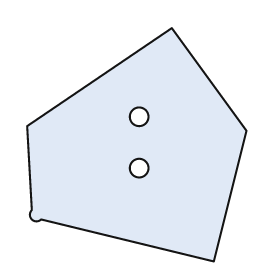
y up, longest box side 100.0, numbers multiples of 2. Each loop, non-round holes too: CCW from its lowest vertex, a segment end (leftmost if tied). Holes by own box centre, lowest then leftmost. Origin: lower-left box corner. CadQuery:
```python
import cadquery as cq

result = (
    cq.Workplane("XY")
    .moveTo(80.0, 0.0)
    .lineTo(94.0, 56.0)
    .lineTo(62.0, 100.0)
    .lineTo(0.0, 58.0)
    .lineTo(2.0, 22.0)
    .threePointArc((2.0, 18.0), (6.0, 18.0))
    .close()
    .moveTo(48.0, 40.0)
    .circle(4.0)
    .moveTo(48.0, 62.0)
    .circle(4.0)
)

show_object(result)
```